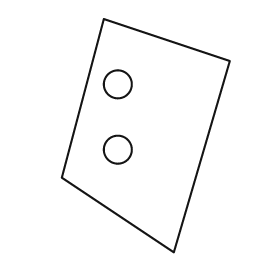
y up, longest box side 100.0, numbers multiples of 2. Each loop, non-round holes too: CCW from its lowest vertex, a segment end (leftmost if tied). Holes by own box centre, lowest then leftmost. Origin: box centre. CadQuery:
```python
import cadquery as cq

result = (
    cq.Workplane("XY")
    .moveTo(12.0, -50.0)
    .lineTo(36.0, 32.0)
    .lineTo(-18.0, 50.0)
    .lineTo(-36.0, -18.0)
    .close()
    .moveTo(-12.0, -6.0)
    .circle(6.0)
    .moveTo(-12.0, 22.0)
    .circle(6.0)
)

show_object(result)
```